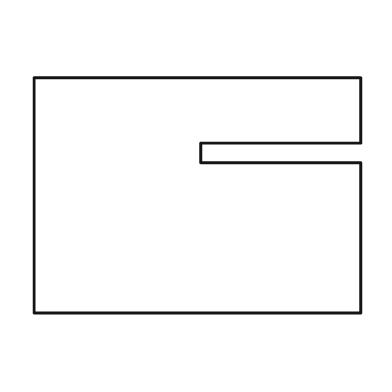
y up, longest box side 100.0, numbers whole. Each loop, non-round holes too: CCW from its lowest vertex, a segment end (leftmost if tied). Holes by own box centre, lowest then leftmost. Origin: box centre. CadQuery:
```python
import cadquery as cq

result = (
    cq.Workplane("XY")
    .moveTo(-50.0, -36.0)
    .lineTo(50.0, -36.0)
    .lineTo(50.0, 10.0)
    .lineTo(1.0, 10.0)
    .lineTo(1.0, 16.0)
    .lineTo(50.0, 16.0)
    .lineTo(50.0, 36.0)
    .lineTo(-50.0, 36.0)
    .close()
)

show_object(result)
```